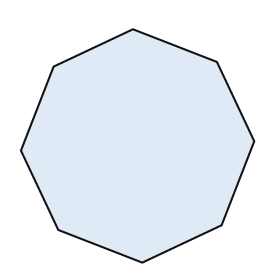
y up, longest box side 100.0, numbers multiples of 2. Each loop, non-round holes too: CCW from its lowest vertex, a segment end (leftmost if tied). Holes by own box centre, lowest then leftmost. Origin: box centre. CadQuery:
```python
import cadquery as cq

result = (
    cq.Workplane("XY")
    .moveTo(2.0, -50.0)
    .lineTo(36.0, -34.0)
    .lineTo(50.0, 2.0)
    .lineTo(34.0, 36.0)
    .lineTo(-2.0, 50.0)
    .lineTo(-36.0, 34.0)
    .lineTo(-50.0, -2.0)
    .lineTo(-34.0, -36.0)
    .close()
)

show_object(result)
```